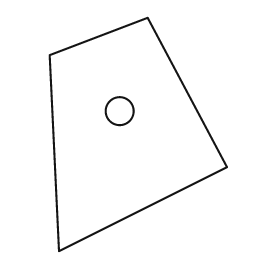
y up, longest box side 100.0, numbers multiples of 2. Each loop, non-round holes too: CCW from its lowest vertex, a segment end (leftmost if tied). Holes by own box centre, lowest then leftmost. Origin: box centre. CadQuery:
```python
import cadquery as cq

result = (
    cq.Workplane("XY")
    .moveTo(-34.0, -50.0)
    .lineTo(38.0, -14.0)
    .lineTo(4.0, 50.0)
    .lineTo(-38.0, 34.0)
    .close()
    .moveTo(-8.0, 10.0)
    .circle(6.0)
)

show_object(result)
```